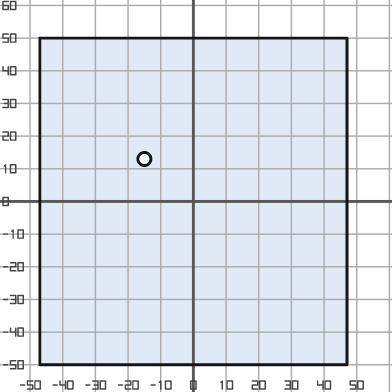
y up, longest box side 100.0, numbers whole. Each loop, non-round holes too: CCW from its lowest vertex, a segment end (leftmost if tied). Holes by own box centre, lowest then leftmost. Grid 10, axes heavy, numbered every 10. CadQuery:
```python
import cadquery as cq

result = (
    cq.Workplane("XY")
    .moveTo(-47.0, -50.0)
    .lineTo(47.0, -50.0)
    .lineTo(47.0, 50.0)
    .lineTo(-47.0, 50.0)
    .close()
    .moveTo(-15.0, 13.0)
    .circle(2.0)
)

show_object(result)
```